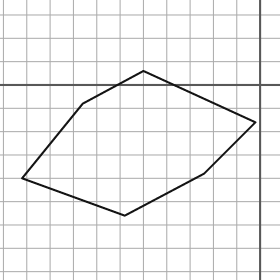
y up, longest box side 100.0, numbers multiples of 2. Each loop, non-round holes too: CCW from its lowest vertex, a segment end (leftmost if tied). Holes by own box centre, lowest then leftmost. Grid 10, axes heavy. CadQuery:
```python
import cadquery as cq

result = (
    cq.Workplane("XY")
    .moveTo(-58.0, -56.0)
    .lineTo(-24.0, -38.0)
    .lineTo(-2.0, -16.0)
    .lineTo(-50.0, 6.0)
    .lineTo(-76.0, -8.0)
    .lineTo(-102.0, -40.0)
    .close()
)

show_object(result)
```